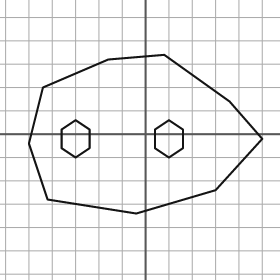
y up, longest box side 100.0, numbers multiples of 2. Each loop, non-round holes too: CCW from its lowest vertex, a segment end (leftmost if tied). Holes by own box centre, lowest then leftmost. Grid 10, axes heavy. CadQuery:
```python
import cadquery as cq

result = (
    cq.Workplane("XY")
    .moveTo(-4.0, -34.0)
    .lineTo(30.0, -24.0)
    .lineTo(50.0, -2.0)
    .lineTo(36.0, 14.0)
    .lineTo(8.0, 34.0)
    .lineTo(-16.0, 32.0)
    .lineTo(-44.0, 20.0)
    .lineTo(-50.0, -4.0)
    .lineTo(-42.0, -28.0)
    .close()
    .moveTo(-30.0, -10.0)
    .lineTo(-24.0, -6.0)
    .lineTo(-24.0, 2.0)
    .lineTo(-30.0, 6.0)
    .lineTo(-36.0, 2.0)
    .lineTo(-36.0, -6.0)
    .close()
    .moveTo(10.0, -10.0)
    .lineTo(16.0, -6.0)
    .lineTo(16.0, 2.0)
    .lineTo(10.0, 6.0)
    .lineTo(4.0, 2.0)
    .lineTo(4.0, -6.0)
    .close()
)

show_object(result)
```